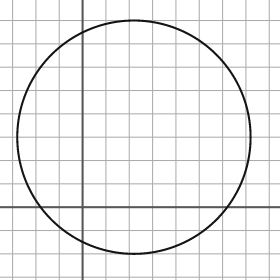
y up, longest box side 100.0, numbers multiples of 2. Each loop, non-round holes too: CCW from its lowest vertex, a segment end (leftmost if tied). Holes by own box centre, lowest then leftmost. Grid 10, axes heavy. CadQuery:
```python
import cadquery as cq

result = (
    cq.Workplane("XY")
    .moveTo(22.0, 30.0)
    .circle(50.0)
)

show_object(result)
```